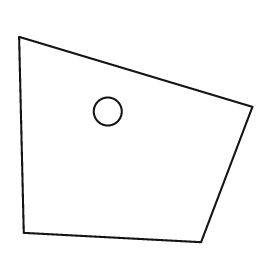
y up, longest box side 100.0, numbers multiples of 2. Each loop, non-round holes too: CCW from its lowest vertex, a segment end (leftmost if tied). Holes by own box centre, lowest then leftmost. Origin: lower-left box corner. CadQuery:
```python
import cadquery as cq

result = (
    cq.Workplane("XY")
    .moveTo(78.0, 0.0)
    .lineTo(100.0, 58.0)
    .lineTo(0.0, 88.0)
    .lineTo(2.0, 4.0)
    .close()
    .moveTo(38.0, 56.0)
    .circle(6.0)
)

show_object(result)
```